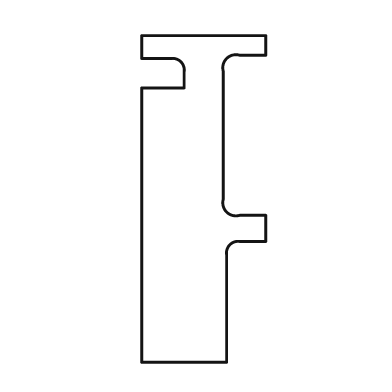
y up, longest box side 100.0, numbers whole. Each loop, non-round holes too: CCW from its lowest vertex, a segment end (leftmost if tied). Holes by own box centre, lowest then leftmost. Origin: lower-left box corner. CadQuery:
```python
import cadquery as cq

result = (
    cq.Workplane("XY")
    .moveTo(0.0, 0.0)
    .lineTo(26.0, 0.0)
    .lineTo(26.0, 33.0)
    .threePointArc((27.0, 36.0), (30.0, 37.0))
    .lineTo(38.0, 37.0)
    .lineTo(38.0, 45.0)
    .lineTo(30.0, 45.0)
    .threePointArc((26.0, 46.0), (25.0, 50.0))
    .lineTo(25.0, 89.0)
    .threePointArc((26.0, 93.0), (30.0, 94.0))
    .lineTo(38.0, 94.0)
    .lineTo(38.0, 100.0)
    .lineTo(0.0, 100.0)
    .lineTo(0.0, 93.0)
    .lineTo(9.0, 93.0)
    .threePointArc((12.0, 92.0), (13.0, 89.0))
    .lineTo(13.0, 84.0)
    .lineTo(0.0, 84.0)
    .close()
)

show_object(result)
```